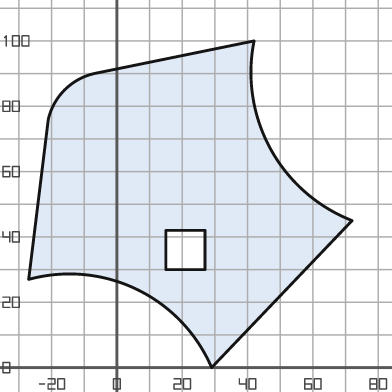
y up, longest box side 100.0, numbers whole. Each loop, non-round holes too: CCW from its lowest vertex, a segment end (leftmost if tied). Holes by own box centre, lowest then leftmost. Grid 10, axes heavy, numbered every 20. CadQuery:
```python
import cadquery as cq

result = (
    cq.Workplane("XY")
    .moveTo(29.0, 0.0)
    .lineTo(72.0, 45.0)
    .threePointArc((47.0, 67.0), (42.0, 100.0))
    .lineTo(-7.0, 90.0)
    .threePointArc((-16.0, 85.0), (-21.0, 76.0))
    .lineTo(-27.0, 27.0)
    .threePointArc((6.0, 24.0), (29.0, 0.0))
    .close()
    .moveTo(15.0, 30.0)
    .lineTo(27.0, 30.0)
    .lineTo(27.0, 42.0)
    .lineTo(15.0, 42.0)
    .close()
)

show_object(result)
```